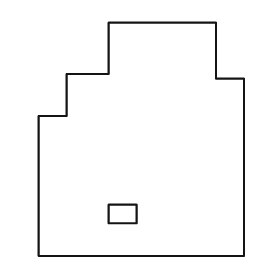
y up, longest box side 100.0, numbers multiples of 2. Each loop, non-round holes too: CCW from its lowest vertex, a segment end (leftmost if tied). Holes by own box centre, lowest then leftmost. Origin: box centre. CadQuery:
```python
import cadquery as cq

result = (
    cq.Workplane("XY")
    .moveTo(-44.0, -50.0)
    .lineTo(44.0, -50.0)
    .lineTo(44.0, 26.0)
    .lineTo(32.0, 26.0)
    .lineTo(32.0, 50.0)
    .lineTo(-14.0, 50.0)
    .lineTo(-14.0, 28.0)
    .lineTo(-32.0, 28.0)
    .lineTo(-32.0, 10.0)
    .lineTo(-44.0, 10.0)
    .close()
    .moveTo(-14.0, -36.0)
    .lineTo(-2.0, -36.0)
    .lineTo(-2.0, -28.0)
    .lineTo(-14.0, -28.0)
    .close()
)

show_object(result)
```